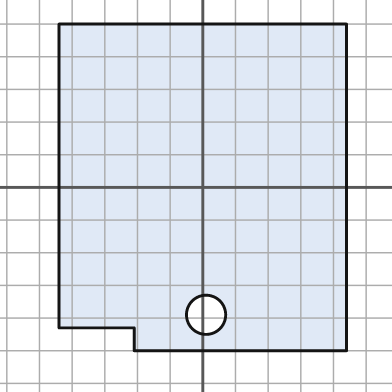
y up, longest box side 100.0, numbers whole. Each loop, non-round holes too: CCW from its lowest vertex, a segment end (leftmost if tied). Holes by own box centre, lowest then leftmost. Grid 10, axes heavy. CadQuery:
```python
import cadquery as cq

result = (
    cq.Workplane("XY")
    .moveTo(-21.0, -50.0)
    .lineTo(44.0, -50.0)
    .lineTo(44.0, 50.0)
    .lineTo(-44.0, 50.0)
    .lineTo(-44.0, -43.0)
    .lineTo(-21.0, -43.0)
    .close()
    .moveTo(1.0, -39.0)
    .circle(6.0)
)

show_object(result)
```